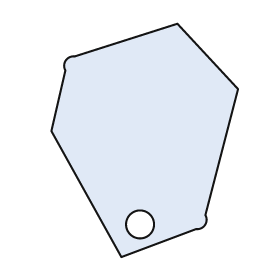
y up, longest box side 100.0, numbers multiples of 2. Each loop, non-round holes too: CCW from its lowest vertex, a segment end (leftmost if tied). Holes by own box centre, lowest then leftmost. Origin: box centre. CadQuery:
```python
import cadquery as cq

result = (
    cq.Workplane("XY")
    .moveTo(-10.0, -50.0)
    .lineTo(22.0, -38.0)
    .threePointArc((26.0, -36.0), (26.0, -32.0))
    .lineTo(40.0, 22.0)
    .lineTo(14.0, 50.0)
    .lineTo(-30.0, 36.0)
    .threePointArc((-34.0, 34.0), (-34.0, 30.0))
    .lineTo(-40.0, 4.0)
    .close()
    .moveTo(-2.0, -36.0)
    .circle(6.0)
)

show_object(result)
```